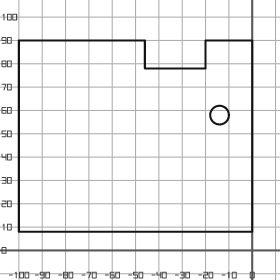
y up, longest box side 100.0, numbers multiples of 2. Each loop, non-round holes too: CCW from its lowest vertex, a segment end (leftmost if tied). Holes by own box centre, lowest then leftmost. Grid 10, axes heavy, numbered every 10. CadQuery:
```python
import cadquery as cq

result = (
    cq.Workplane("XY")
    .moveTo(-100.0, 8.0)
    .lineTo(0.0, 8.0)
    .lineTo(0.0, 90.0)
    .lineTo(-20.0, 90.0)
    .lineTo(-20.0, 78.0)
    .lineTo(-46.0, 78.0)
    .lineTo(-46.0, 90.0)
    .lineTo(-100.0, 90.0)
    .close()
    .moveTo(-14.0, 58.0)
    .circle(4.0)
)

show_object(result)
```